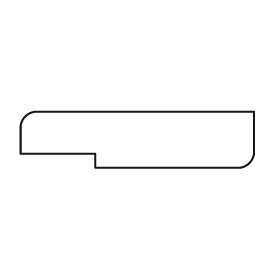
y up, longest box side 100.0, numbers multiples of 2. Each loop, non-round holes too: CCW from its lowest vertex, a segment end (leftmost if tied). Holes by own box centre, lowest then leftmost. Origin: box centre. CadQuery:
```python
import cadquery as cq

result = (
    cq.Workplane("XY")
    .moveTo(-18.0, -12.0)
    .lineTo(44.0, -12.0)
    .threePointArc((48.0, -10.0), (50.0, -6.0))
    .lineTo(50.0, 12.0)
    .lineTo(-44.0, 12.0)
    .threePointArc((-48.0, 10.0), (-50.0, 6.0))
    .lineTo(-50.0, -6.0)
    .lineTo(-18.0, -6.0)
    .close()
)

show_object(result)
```